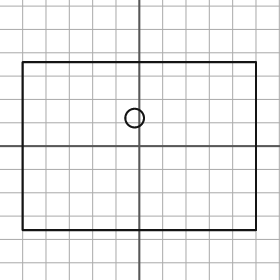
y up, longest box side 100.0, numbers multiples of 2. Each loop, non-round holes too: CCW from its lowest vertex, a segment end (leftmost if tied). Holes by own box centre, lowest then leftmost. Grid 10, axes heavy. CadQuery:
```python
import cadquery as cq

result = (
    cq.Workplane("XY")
    .moveTo(-50.0, -36.0)
    .lineTo(50.0, -36.0)
    .lineTo(50.0, 36.0)
    .lineTo(-50.0, 36.0)
    .close()
    .moveTo(-2.0, 12.0)
    .circle(4.0)
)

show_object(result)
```